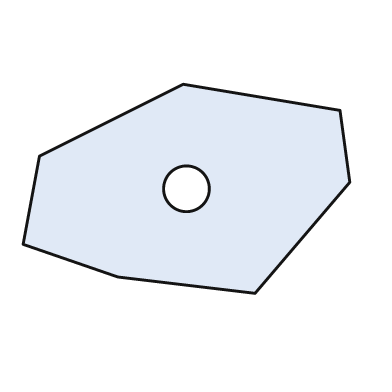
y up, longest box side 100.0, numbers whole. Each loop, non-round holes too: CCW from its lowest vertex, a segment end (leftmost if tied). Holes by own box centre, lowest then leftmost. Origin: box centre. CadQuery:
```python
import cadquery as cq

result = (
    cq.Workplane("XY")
    .moveTo(21.0, -32.0)
    .lineTo(50.0, 2.0)
    .lineTo(47.0, 24.0)
    .lineTo(-1.0, 32.0)
    .lineTo(-45.0, 10.0)
    .lineTo(-50.0, -17.0)
    .lineTo(-21.0, -27.0)
    .close()
    .moveTo(0.0, 0.0)
    .circle(7.0)
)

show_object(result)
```